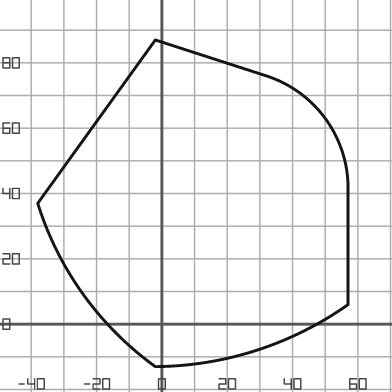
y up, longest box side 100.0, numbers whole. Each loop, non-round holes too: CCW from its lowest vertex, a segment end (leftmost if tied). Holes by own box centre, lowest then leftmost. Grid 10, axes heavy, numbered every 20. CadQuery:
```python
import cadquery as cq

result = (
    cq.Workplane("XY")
    .moveTo(-2.0, -13.0)
    .threePointArc((29.0, -8.0), (57.0, 6.0))
    .lineTo(57.0, 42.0)
    .threePointArc((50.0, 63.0), (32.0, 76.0))
    .lineTo(-2.0, 87.0)
    .lineTo(-38.0, 37.0)
    .threePointArc((-24.0, 9.0), (-2.0, -13.0))
    .close()
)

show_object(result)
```